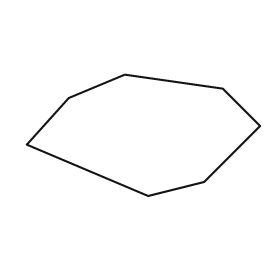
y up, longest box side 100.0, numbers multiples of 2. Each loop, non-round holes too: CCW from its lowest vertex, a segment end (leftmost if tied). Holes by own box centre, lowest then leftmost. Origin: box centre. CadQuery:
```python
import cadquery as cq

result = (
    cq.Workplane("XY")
    .moveTo(2.0, -26.0)
    .lineTo(26.0, -20.0)
    .lineTo(50.0, 4.0)
    .lineTo(34.0, 20.0)
    .lineTo(-8.0, 26.0)
    .lineTo(-32.0, 16.0)
    .lineTo(-50.0, -4.0)
    .close()
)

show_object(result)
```